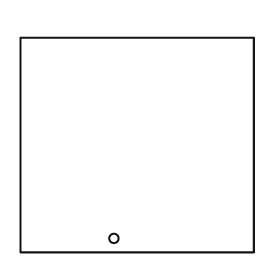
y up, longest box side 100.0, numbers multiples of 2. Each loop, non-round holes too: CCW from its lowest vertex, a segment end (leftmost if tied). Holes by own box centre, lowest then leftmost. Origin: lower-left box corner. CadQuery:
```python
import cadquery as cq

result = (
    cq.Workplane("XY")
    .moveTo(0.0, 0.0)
    .lineTo(100.0, 0.0)
    .lineTo(100.0, 92.0)
    .lineTo(0.0, 92.0)
    .close()
    .moveTo(40.0, 6.0)
    .circle(2.0)
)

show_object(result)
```